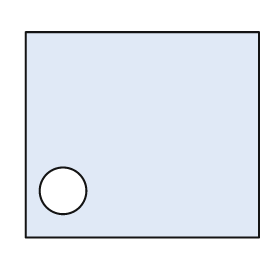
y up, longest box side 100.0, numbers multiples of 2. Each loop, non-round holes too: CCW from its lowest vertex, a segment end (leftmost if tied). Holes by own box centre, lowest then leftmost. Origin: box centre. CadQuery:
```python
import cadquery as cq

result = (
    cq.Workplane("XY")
    .moveTo(-50.0, -44.0)
    .lineTo(50.0, -44.0)
    .lineTo(50.0, 44.0)
    .lineTo(-50.0, 44.0)
    .close()
    .moveTo(-34.0, -24.0)
    .circle(10.0)
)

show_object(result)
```